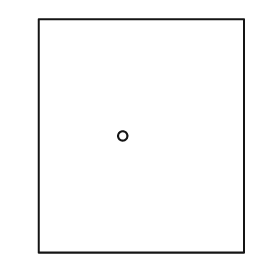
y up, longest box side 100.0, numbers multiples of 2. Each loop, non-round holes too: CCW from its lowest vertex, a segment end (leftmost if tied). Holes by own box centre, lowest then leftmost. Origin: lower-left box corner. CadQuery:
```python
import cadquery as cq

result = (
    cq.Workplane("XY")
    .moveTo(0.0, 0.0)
    .lineTo(88.0, 0.0)
    .lineTo(88.0, 100.0)
    .lineTo(0.0, 100.0)
    .close()
    .moveTo(36.0, 50.0)
    .circle(2.0)
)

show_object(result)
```